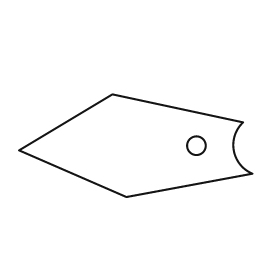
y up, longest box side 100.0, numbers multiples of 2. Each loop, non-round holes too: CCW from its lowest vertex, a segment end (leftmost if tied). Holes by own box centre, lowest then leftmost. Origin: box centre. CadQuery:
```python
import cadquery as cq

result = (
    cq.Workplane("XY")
    .moveTo(-4.0, -22.0)
    .lineTo(50.0, -12.0)
    .threePointArc((42.0, -2.0), (46.0, 10.0))
    .lineTo(-10.0, 22.0)
    .lineTo(-50.0, -2.0)
    .close()
    .moveTo(26.0, 0.0)
    .circle(4.0)
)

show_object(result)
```